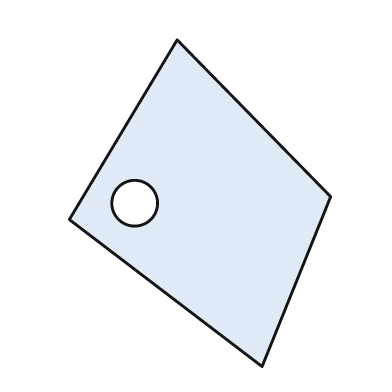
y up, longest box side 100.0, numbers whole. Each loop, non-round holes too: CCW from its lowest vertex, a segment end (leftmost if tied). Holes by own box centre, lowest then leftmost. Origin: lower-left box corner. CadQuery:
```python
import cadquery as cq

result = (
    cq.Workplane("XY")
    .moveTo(59.0, 0.0)
    .lineTo(80.0, 52.0)
    .lineTo(33.0, 100.0)
    .lineTo(0.0, 45.0)
    .close()
    .moveTo(20.0, 50.0)
    .circle(7.0)
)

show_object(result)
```